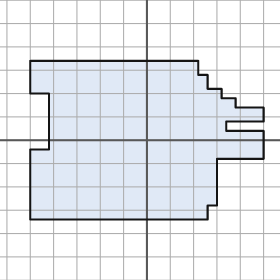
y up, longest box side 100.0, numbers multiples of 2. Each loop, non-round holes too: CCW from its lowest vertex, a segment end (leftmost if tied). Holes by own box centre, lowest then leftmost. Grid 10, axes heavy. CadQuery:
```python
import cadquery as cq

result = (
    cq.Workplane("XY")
    .moveTo(-50.0, -34.0)
    .lineTo(26.0, -34.0)
    .lineTo(26.0, -28.0)
    .lineTo(30.0, -28.0)
    .lineTo(30.0, -8.0)
    .lineTo(50.0, -8.0)
    .lineTo(50.0, 4.0)
    .lineTo(34.0, 4.0)
    .lineTo(34.0, 8.0)
    .lineTo(50.0, 8.0)
    .lineTo(50.0, 14.0)
    .lineTo(38.0, 14.0)
    .lineTo(38.0, 18.0)
    .lineTo(32.0, 18.0)
    .lineTo(32.0, 22.0)
    .lineTo(26.0, 22.0)
    .lineTo(26.0, 28.0)
    .lineTo(22.0, 28.0)
    .lineTo(22.0, 34.0)
    .lineTo(-50.0, 34.0)
    .lineTo(-50.0, 20.0)
    .lineTo(-42.0, 20.0)
    .lineTo(-42.0, -4.0)
    .lineTo(-50.0, -4.0)
    .close()
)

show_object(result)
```